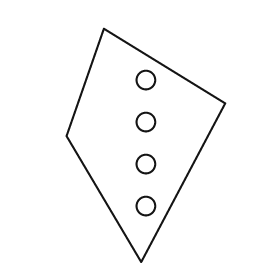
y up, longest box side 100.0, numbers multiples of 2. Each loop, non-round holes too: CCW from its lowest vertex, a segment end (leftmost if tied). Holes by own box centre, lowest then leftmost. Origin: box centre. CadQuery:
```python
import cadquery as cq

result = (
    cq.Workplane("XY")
    .moveTo(-2.0, -50.0)
    .lineTo(34.0, 18.0)
    .lineTo(-18.0, 50.0)
    .lineTo(-34.0, 4.0)
    .close()
    .moveTo(0.0, -26.0)
    .circle(4.0)
    .moveTo(0.0, -8.0)
    .circle(4.0)
    .moveTo(0.0, 10.0)
    .circle(4.0)
    .moveTo(0.0, 28.0)
    .circle(4.0)
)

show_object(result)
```